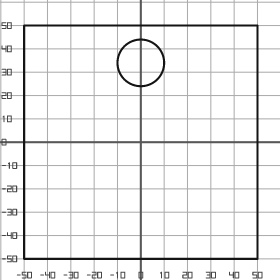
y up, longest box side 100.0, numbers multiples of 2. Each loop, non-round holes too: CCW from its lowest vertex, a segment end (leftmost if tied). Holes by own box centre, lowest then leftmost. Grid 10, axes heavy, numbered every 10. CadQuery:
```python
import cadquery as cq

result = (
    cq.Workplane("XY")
    .moveTo(-50.0, -50.0)
    .lineTo(50.0, -50.0)
    .lineTo(50.0, 50.0)
    .lineTo(-50.0, 50.0)
    .close()
    .moveTo(0.0, 34.0)
    .circle(10.0)
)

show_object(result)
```